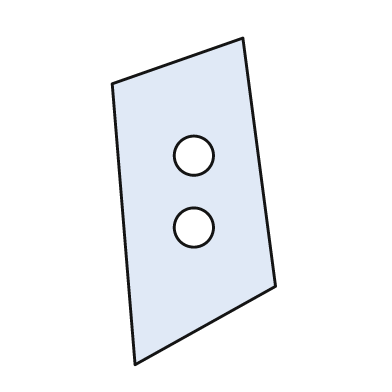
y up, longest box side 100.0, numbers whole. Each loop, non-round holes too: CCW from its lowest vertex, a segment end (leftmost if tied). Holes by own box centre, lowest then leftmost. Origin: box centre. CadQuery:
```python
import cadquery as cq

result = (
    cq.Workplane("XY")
    .moveTo(-18.0, -50.0)
    .lineTo(25.0, -26.0)
    .lineTo(15.0, 50.0)
    .lineTo(-25.0, 36.0)
    .close()
    .moveTo(0.0, -8.0)
    .circle(6.0)
    .moveTo(0.0, 14.0)
    .circle(6.0)
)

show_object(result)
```